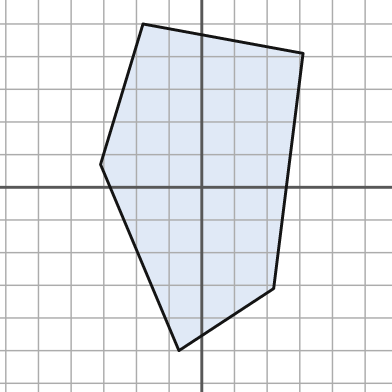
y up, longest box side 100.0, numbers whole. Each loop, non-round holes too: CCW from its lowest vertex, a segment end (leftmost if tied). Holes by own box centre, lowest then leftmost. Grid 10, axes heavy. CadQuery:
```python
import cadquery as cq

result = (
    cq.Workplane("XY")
    .moveTo(-7.0, -50.0)
    .lineTo(22.0, -31.0)
    .lineTo(31.0, 41.0)
    .lineTo(-18.0, 50.0)
    .lineTo(-31.0, 7.0)
    .close()
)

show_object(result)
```